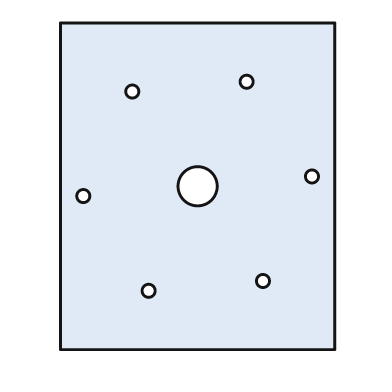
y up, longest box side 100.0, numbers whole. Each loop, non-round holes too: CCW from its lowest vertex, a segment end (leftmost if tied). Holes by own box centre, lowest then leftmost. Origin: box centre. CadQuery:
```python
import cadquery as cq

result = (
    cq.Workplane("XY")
    .moveTo(-42.0, -50.0)
    .lineTo(42.0, -50.0)
    .lineTo(42.0, 50.0)
    .lineTo(-42.0, 50.0)
    .close()
    .moveTo(-15.0, -32.0)
    .circle(2.0)
    .moveTo(20.0, -29.0)
    .circle(2.0)
    .moveTo(-35.0, -3.0)
    .circle(2.0)
    .moveTo(0.0, 0.0)
    .circle(6.0)
    .moveTo(35.0, 3.0)
    .circle(2.0)
    .moveTo(-20.0, 29.0)
    .circle(2.0)
    .moveTo(15.0, 32.0)
    .circle(2.0)
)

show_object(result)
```